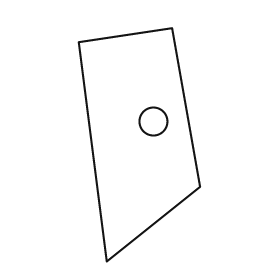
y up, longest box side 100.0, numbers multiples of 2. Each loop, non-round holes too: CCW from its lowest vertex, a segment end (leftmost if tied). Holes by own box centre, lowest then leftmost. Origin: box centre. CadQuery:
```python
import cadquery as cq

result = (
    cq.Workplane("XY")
    .moveTo(-14.0, -50.0)
    .lineTo(26.0, -18.0)
    .lineTo(14.0, 50.0)
    .lineTo(-26.0, 44.0)
    .close()
    .moveTo(6.0, 10.0)
    .circle(6.0)
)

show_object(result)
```